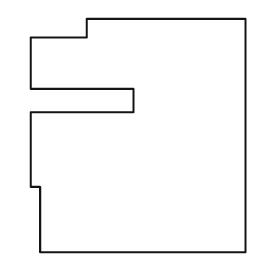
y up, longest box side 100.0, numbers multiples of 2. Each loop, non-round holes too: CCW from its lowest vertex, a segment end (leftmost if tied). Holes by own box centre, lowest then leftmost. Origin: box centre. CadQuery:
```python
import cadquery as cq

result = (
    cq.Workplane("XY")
    .moveTo(-42.0, -50.0)
    .lineTo(46.0, -50.0)
    .lineTo(46.0, 50.0)
    .lineTo(-22.0, 50.0)
    .lineTo(-22.0, 42.0)
    .lineTo(-46.0, 42.0)
    .lineTo(-46.0, 20.0)
    .lineTo(-2.0, 20.0)
    .lineTo(-2.0, 10.0)
    .lineTo(-46.0, 10.0)
    .lineTo(-46.0, -22.0)
    .lineTo(-42.0, -22.0)
    .close()
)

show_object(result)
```